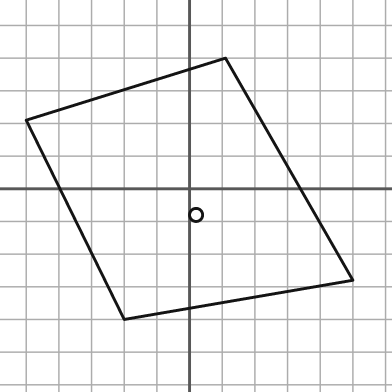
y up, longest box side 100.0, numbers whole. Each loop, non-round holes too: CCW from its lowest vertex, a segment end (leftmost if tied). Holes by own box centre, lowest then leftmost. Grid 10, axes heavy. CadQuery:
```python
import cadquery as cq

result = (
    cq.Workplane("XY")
    .moveTo(-20.0, -40.0)
    .lineTo(50.0, -28.0)
    .lineTo(11.0, 40.0)
    .lineTo(-50.0, 21.0)
    .close()
    .moveTo(2.0, -8.0)
    .circle(2.0)
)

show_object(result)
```